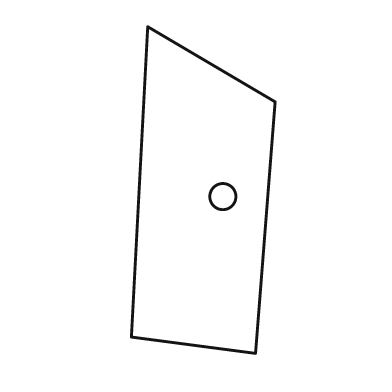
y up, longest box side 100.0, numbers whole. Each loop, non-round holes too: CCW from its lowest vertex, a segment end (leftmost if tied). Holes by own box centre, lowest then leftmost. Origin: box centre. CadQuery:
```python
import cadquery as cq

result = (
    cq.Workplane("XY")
    .moveTo(16.0, -50.0)
    .lineTo(22.0, 27.0)
    .lineTo(-17.0, 50.0)
    .lineTo(-22.0, -45.0)
    .close()
    .moveTo(6.0, -2.0)
    .circle(4.0)
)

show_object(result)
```